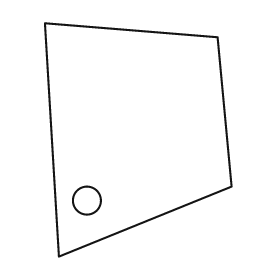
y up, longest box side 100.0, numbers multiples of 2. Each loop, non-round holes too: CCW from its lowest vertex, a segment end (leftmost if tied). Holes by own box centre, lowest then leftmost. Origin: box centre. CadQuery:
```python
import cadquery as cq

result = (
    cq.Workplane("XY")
    .moveTo(-34.0, -50.0)
    .lineTo(40.0, -20.0)
    .lineTo(34.0, 44.0)
    .lineTo(-40.0, 50.0)
    .close()
    .moveTo(-22.0, -26.0)
    .circle(6.0)
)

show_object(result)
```